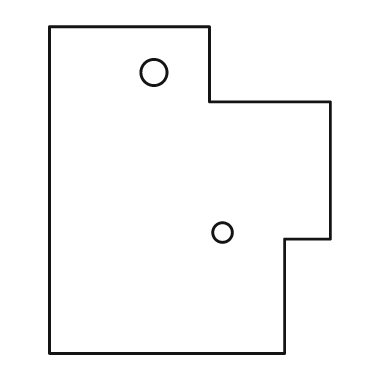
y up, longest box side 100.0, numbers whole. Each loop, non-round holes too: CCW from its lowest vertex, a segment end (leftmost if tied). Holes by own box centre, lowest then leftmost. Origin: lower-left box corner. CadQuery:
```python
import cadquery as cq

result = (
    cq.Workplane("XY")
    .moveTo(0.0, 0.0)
    .lineTo(72.0, 0.0)
    .lineTo(72.0, 35.0)
    .lineTo(86.0, 35.0)
    .lineTo(86.0, 77.0)
    .lineTo(49.0, 77.0)
    .lineTo(49.0, 100.0)
    .lineTo(0.0, 100.0)
    .close()
    .moveTo(53.0, 37.0)
    .circle(3.0)
    .moveTo(32.0, 86.0)
    .circle(4.0)
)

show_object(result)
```